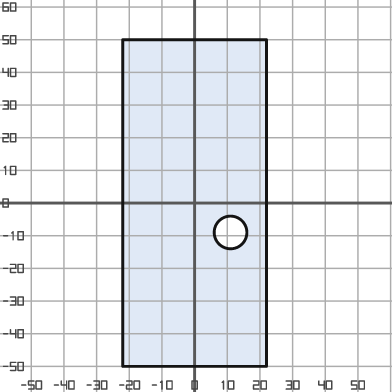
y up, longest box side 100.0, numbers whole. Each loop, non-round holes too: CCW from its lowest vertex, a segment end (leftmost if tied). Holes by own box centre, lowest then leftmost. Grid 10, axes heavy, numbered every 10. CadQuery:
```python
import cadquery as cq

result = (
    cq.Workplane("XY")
    .moveTo(-22.0, -50.0)
    .lineTo(22.0, -50.0)
    .lineTo(22.0, 50.0)
    .lineTo(-22.0, 50.0)
    .close()
    .moveTo(11.0, -9.0)
    .circle(5.0)
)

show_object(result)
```